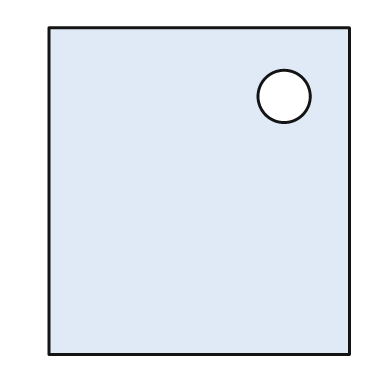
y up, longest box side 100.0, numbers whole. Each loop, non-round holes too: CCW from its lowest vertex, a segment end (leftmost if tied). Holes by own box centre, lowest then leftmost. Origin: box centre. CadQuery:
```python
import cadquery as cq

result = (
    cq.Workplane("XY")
    .moveTo(-46.0, -50.0)
    .lineTo(46.0, -50.0)
    .lineTo(46.0, 50.0)
    .lineTo(-46.0, 50.0)
    .close()
    .moveTo(26.0, 29.0)
    .circle(8.0)
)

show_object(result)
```